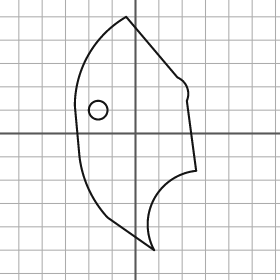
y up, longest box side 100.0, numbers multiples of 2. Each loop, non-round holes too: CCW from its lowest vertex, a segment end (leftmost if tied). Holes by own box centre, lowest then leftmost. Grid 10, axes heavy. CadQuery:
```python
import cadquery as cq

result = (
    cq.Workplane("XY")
    .moveTo(8.0, -50.0)
    .threePointArc((8.0, -28.0), (26.0, -16.0))
    .lineTo(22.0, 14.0)
    .threePointArc((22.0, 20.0), (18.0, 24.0))
    .lineTo(-4.0, 50.0)
    .threePointArc((-20.0, 34.0), (-26.0, 12.0))
    .lineTo(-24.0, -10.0)
    .threePointArc((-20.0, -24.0), (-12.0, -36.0))
    .close()
    .moveTo(-16.0, 10.0)
    .circle(4.0)
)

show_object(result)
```